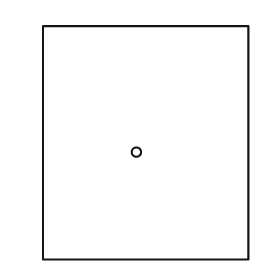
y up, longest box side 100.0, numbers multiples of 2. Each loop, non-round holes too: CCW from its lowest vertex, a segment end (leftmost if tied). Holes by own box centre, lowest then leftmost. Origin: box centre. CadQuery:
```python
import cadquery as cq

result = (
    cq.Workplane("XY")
    .moveTo(-44.0, -50.0)
    .lineTo(44.0, -50.0)
    .lineTo(44.0, 50.0)
    .lineTo(-44.0, 50.0)
    .close()
    .moveTo(-4.0, -4.0)
    .circle(2.0)
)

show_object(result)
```